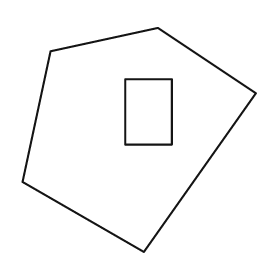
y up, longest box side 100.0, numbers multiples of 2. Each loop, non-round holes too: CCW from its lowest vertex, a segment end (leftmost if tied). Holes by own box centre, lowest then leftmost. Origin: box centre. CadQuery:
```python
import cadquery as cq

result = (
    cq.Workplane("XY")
    .moveTo(2.0, -48.0)
    .lineTo(50.0, 20.0)
    .lineTo(8.0, 48.0)
    .lineTo(-38.0, 38.0)
    .lineTo(-50.0, -18.0)
    .close()
    .moveTo(-6.0, -2.0)
    .lineTo(14.0, -2.0)
    .lineTo(14.0, 26.0)
    .lineTo(-6.0, 26.0)
    .close()
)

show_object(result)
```